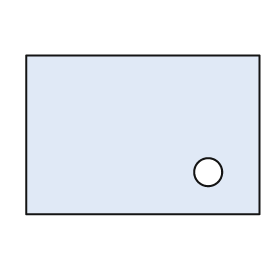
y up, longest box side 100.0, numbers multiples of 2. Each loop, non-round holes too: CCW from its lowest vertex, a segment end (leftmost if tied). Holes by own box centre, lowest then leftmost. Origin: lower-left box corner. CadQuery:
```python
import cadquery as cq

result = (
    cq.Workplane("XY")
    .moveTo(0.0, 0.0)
    .lineTo(100.0, 0.0)
    .lineTo(100.0, 68.0)
    .lineTo(0.0, 68.0)
    .close()
    .moveTo(78.0, 18.0)
    .circle(6.0)
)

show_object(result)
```